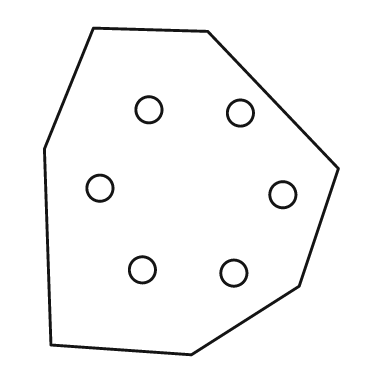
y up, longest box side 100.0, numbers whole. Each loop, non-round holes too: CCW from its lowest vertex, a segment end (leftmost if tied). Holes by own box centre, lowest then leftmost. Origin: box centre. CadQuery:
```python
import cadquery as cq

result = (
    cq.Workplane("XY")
    .moveTo(0.0, -50.0)
    .lineTo(33.0, -29.0)
    .lineTo(45.0, 7.0)
    .lineTo(5.0, 49.0)
    .lineTo(-30.0, 50.0)
    .lineTo(-45.0, 13.0)
    .lineTo(-43.0, -47.0)
    .close()
    .moveTo(13.0, -25.0)
    .circle(4.0)
    .moveTo(-15.0, -24.0)
    .circle(4.0)
    .moveTo(28.0, -1.0)
    .circle(4.0)
    .moveTo(-28.0, 1.0)
    .circle(4.0)
    .moveTo(15.0, 24.0)
    .circle(4.0)
    .moveTo(-13.0, 25.0)
    .circle(4.0)
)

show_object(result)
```